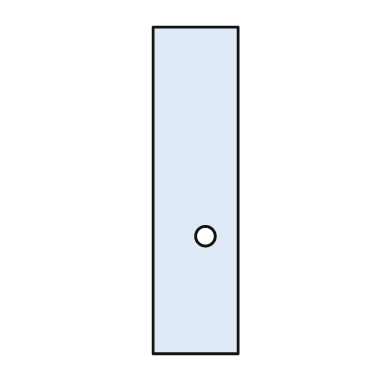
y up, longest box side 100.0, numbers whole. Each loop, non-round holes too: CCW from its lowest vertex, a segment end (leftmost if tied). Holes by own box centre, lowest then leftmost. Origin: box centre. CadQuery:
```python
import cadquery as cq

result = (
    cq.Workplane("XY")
    .moveTo(-13.0, -50.0)
    .lineTo(13.0, -50.0)
    .lineTo(13.0, 50.0)
    .lineTo(-13.0, 50.0)
    .close()
    .moveTo(3.0, -14.0)
    .circle(3.0)
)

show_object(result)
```